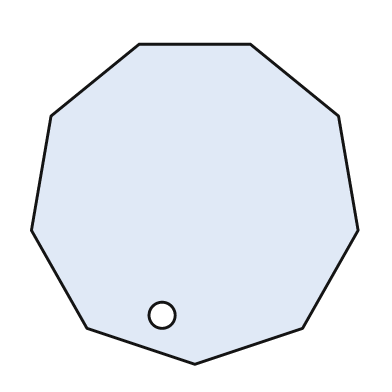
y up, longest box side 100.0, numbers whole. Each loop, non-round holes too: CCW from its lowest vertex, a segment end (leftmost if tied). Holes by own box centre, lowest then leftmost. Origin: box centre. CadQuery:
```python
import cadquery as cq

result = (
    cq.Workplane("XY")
    .moveTo(0.0, -49.0)
    .lineTo(33.0, -38.0)
    .lineTo(50.0, -8.0)
    .lineTo(44.0, 27.0)
    .lineTo(17.0, 49.0)
    .lineTo(-17.0, 49.0)
    .lineTo(-44.0, 27.0)
    .lineTo(-50.0, -8.0)
    .lineTo(-33.0, -38.0)
    .close()
    .moveTo(-10.0, -34.0)
    .circle(4.0)
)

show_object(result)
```